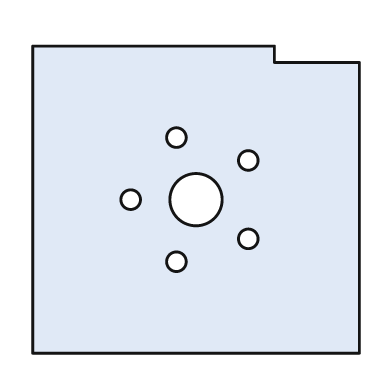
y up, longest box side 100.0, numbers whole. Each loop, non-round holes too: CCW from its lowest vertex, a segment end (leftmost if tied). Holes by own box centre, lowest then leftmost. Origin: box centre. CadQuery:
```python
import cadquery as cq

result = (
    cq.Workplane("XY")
    .moveTo(-50.0, -47.0)
    .lineTo(50.0, -47.0)
    .lineTo(50.0, 42.0)
    .lineTo(24.0, 42.0)
    .lineTo(24.0, 47.0)
    .lineTo(-50.0, 47.0)
    .close()
    .moveTo(-6.0, -19.0)
    .circle(3.0)
    .moveTo(16.0, -12.0)
    .circle(3.0)
    .moveTo(-20.0, 0.0)
    .circle(3.0)
    .moveTo(0.0, 0.0)
    .circle(8.0)
    .moveTo(16.0, 12.0)
    .circle(3.0)
    .moveTo(-6.0, 19.0)
    .circle(3.0)
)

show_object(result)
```